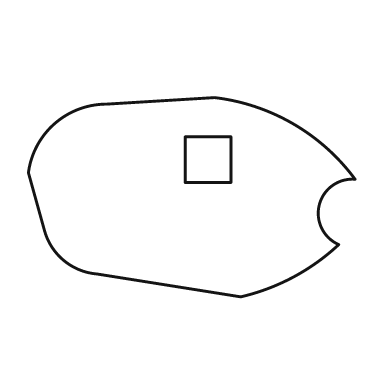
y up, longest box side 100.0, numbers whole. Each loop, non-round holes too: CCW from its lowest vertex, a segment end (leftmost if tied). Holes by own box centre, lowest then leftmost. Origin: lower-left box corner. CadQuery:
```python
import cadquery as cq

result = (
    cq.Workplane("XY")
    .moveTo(65.0, 0.0)
    .threePointArc((81.0, 6.0), (95.0, 16.0))
    .threePointArc((89.0, 28.0), (100.0, 36.0))
    .threePointArc((81.0, 53.0), (57.0, 61.0))
    .lineTo(24.0, 59.0)
    .threePointArc((8.0, 53.0), (0.0, 38.0))
    .lineTo(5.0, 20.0)
    .threePointArc((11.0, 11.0), (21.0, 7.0))
    .close()
    .moveTo(48.0, 35.0)
    .lineTo(62.0, 35.0)
    .lineTo(62.0, 49.0)
    .lineTo(48.0, 49.0)
    .close()
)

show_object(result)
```